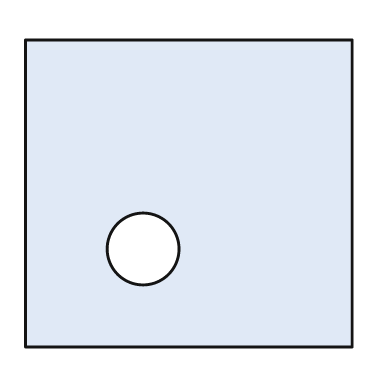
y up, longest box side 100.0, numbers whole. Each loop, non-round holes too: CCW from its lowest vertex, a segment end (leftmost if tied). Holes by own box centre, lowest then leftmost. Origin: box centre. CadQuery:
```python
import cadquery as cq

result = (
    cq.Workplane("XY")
    .moveTo(-50.0, -47.0)
    .lineTo(50.0, -47.0)
    .lineTo(50.0, 47.0)
    .lineTo(-50.0, 47.0)
    .close()
    .moveTo(-14.0, -17.0)
    .circle(11.0)
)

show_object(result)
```